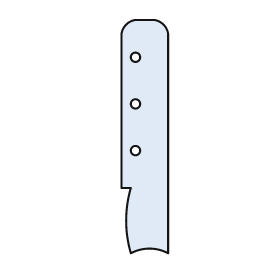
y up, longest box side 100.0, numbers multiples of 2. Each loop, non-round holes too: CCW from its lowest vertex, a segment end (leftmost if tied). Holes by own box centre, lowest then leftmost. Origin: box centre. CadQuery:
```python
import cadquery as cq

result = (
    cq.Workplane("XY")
    .moveTo(-6.0, -50.0)
    .threePointArc((2.0, -48.0), (10.0, -50.0))
    .lineTo(10.0, 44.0)
    .threePointArc((8.0, 48.0), (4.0, 50.0))
    .lineTo(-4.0, 50.0)
    .threePointArc((-8.0, 48.0), (-10.0, 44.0))
    .lineTo(-10.0, -22.0)
    .lineTo(-6.0, -22.0)
    .threePointArc((-8.0, -36.0), (-6.0, -50.0))
    .close()
    .moveTo(-4.0, -6.0)
    .circle(2.0)
    .moveTo(-4.0, 14.0)
    .circle(2.0)
    .moveTo(-4.0, 34.0)
    .circle(2.0)
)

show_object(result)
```